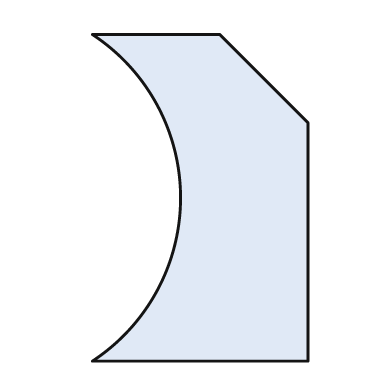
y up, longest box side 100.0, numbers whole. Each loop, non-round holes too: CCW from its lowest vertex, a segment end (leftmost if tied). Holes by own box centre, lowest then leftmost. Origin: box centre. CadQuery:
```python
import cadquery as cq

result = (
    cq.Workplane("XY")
    .moveTo(-33.0, -50.0)
    .lineTo(33.0, -50.0)
    .lineTo(33.0, 23.0)
    .lineTo(6.0, 50.0)
    .lineTo(-33.0, 50.0)
    .threePointArc((-6.0, 0.0), (-33.0, -50.0))
    .close()
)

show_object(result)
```